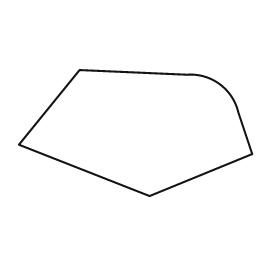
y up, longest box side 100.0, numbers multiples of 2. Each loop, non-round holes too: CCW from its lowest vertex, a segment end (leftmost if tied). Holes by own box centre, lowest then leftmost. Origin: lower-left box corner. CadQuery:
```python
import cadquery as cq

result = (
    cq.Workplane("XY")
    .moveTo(56.0, 0.0)
    .lineTo(100.0, 18.0)
    .lineTo(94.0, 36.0)
    .threePointArc((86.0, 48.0), (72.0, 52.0))
    .lineTo(26.0, 54.0)
    .lineTo(0.0, 22.0)
    .close()
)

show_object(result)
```